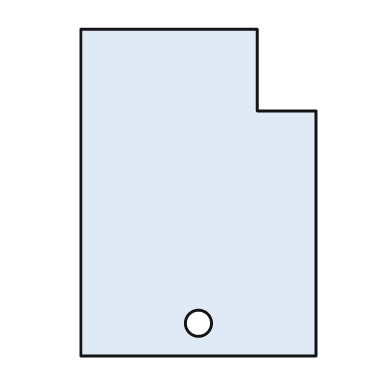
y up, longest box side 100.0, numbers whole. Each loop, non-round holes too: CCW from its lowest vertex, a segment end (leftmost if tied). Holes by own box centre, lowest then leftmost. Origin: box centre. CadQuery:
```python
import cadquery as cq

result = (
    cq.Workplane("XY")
    .moveTo(-36.0, -50.0)
    .lineTo(36.0, -50.0)
    .lineTo(36.0, 25.0)
    .lineTo(18.0, 25.0)
    .lineTo(18.0, 50.0)
    .lineTo(-36.0, 50.0)
    .close()
    .moveTo(0.0, -40.0)
    .circle(4.0)
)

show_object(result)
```